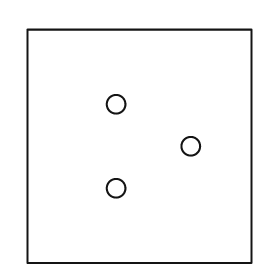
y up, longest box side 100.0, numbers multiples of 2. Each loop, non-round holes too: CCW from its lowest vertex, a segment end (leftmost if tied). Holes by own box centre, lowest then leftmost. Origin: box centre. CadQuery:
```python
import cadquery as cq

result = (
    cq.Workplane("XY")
    .moveTo(-48.0, -50.0)
    .lineTo(48.0, -50.0)
    .lineTo(48.0, 50.0)
    .lineTo(-48.0, 50.0)
    .close()
    .moveTo(-10.0, -18.0)
    .circle(4.0)
    .moveTo(22.0, 0.0)
    .circle(4.0)
    .moveTo(-10.0, 18.0)
    .circle(4.0)
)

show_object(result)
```